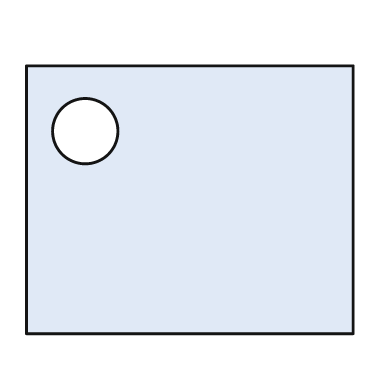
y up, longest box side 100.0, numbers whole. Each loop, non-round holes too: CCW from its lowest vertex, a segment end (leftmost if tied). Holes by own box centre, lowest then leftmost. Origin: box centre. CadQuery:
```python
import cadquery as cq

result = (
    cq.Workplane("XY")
    .moveTo(-50.0, -41.0)
    .lineTo(50.0, -41.0)
    .lineTo(50.0, 41.0)
    .lineTo(-50.0, 41.0)
    .close()
    .moveTo(-32.0, 21.0)
    .circle(10.0)
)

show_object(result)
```